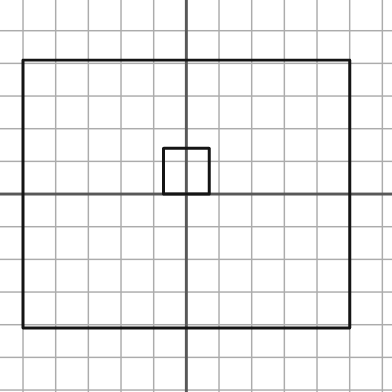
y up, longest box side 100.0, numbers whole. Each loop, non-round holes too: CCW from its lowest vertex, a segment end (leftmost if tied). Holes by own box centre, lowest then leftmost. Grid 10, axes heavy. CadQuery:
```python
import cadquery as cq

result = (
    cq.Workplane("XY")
    .moveTo(-50.0, -41.0)
    .lineTo(50.0, -41.0)
    .lineTo(50.0, 41.0)
    .lineTo(-50.0, 41.0)
    .close()
    .moveTo(-7.0, 0.0)
    .lineTo(7.0, 0.0)
    .lineTo(7.0, 14.0)
    .lineTo(-7.0, 14.0)
    .close()
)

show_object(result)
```